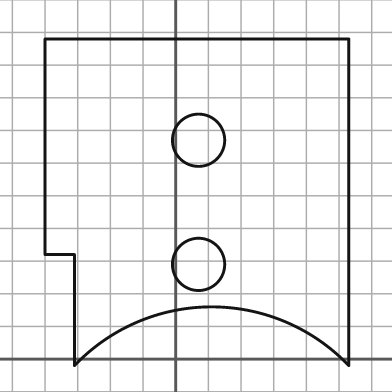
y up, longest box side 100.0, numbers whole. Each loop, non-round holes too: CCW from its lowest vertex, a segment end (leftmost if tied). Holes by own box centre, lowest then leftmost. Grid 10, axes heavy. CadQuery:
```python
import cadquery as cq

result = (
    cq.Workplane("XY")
    .moveTo(-31.0, -2.0)
    .threePointArc((11.0, 16.0), (53.0, -2.0))
    .lineTo(53.0, 98.0)
    .lineTo(-40.0, 98.0)
    .lineTo(-40.0, 32.0)
    .lineTo(-31.0, 32.0)
    .close()
    .moveTo(7.0, 29.0)
    .circle(8.0)
    .moveTo(7.0, 67.0)
    .circle(8.0)
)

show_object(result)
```